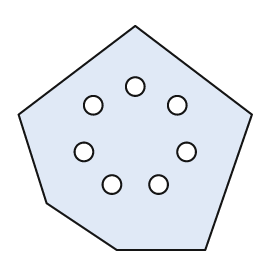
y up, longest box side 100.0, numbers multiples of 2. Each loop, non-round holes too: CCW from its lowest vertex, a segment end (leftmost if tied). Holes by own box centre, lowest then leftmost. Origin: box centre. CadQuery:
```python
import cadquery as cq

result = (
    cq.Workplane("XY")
    .moveTo(-8.0, -48.0)
    .lineTo(30.0, -48.0)
    .lineTo(50.0, 10.0)
    .lineTo(0.0, 48.0)
    .lineTo(-50.0, 10.0)
    .lineTo(-38.0, -28.0)
    .close()
    .moveTo(-10.0, -20.0)
    .circle(4.0)
    .moveTo(10.0, -20.0)
    .circle(4.0)
    .moveTo(-22.0, -6.0)
    .circle(4.0)
    .moveTo(22.0, -6.0)
    .circle(4.0)
    .moveTo(-18.0, 14.0)
    .circle(4.0)
    .moveTo(18.0, 14.0)
    .circle(4.0)
    .moveTo(0.0, 22.0)
    .circle(4.0)
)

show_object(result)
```